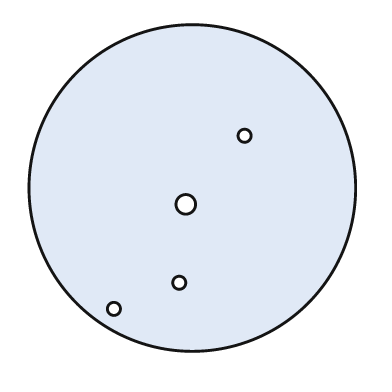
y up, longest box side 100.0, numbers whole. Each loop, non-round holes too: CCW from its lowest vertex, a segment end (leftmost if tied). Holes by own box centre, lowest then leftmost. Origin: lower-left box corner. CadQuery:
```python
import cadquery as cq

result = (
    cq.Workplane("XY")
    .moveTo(50.0, 50.0)
    .circle(50.0)
    .moveTo(26.0, 13.0)
    .circle(2.0)
    .moveTo(46.0, 21.0)
    .circle(2.0)
    .moveTo(48.0, 45.0)
    .circle(3.0)
    .moveTo(66.0, 66.0)
    .circle(2.0)
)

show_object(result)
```